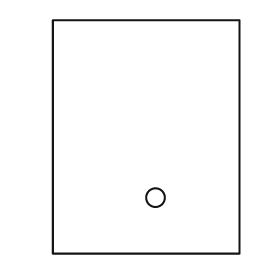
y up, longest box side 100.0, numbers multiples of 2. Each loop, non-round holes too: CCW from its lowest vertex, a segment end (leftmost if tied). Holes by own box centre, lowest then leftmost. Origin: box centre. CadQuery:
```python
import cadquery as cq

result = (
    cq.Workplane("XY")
    .moveTo(-40.0, -50.0)
    .lineTo(40.0, -50.0)
    .lineTo(40.0, 50.0)
    .lineTo(-40.0, 50.0)
    .close()
    .moveTo(4.0, -26.0)
    .circle(4.0)
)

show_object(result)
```